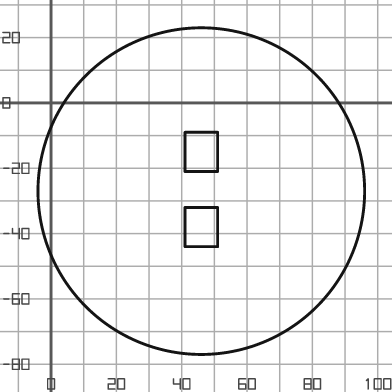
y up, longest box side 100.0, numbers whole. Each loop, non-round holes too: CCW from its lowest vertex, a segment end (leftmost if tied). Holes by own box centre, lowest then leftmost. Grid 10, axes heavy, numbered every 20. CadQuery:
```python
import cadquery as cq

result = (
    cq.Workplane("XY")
    .moveTo(46.0, -27.0)
    .circle(50.0)
    .moveTo(41.0, -44.0)
    .lineTo(51.0, -44.0)
    .lineTo(51.0, -32.0)
    .lineTo(41.0, -32.0)
    .close()
    .moveTo(41.0, -21.0)
    .lineTo(51.0, -21.0)
    .lineTo(51.0, -9.0)
    .lineTo(41.0, -9.0)
    .close()
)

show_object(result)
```